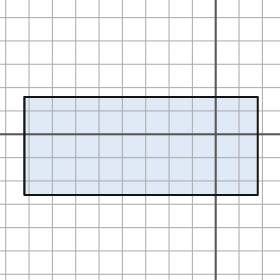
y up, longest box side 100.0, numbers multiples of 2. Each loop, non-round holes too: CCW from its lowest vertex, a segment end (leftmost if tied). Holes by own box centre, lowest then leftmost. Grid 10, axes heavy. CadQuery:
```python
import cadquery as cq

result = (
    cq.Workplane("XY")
    .moveTo(-82.0, -26.0)
    .lineTo(18.0, -26.0)
    .lineTo(18.0, 16.0)
    .lineTo(-82.0, 16.0)
    .close()
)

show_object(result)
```